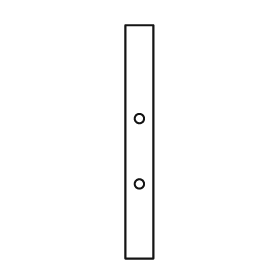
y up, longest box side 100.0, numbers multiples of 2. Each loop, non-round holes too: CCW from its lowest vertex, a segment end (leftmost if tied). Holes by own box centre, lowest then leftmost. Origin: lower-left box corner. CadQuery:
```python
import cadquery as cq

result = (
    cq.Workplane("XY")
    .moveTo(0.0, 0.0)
    .lineTo(12.0, 0.0)
    .lineTo(12.0, 100.0)
    .lineTo(0.0, 100.0)
    .close()
    .moveTo(6.0, 32.0)
    .circle(2.0)
    .moveTo(6.0, 60.0)
    .circle(2.0)
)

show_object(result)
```